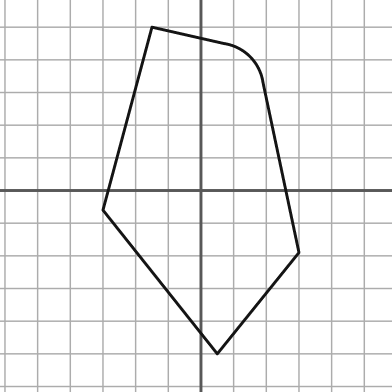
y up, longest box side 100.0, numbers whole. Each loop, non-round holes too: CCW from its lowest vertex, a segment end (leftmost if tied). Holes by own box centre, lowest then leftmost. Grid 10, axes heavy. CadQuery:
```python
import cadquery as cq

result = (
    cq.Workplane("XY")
    .moveTo(5.0, -50.0)
    .lineTo(30.0, -19.0)
    .lineTo(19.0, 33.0)
    .threePointArc((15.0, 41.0), (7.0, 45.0))
    .lineTo(-15.0, 50.0)
    .lineTo(-30.0, -6.0)
    .close()
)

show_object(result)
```